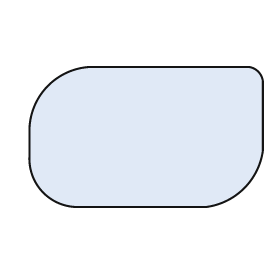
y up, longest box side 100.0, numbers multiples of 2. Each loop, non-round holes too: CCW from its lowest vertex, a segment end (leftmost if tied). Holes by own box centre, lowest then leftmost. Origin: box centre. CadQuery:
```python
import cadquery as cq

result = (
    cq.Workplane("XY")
    .moveTo(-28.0, -30.0)
    .lineTo(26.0, -30.0)
    .threePointArc((42.0, -22.0), (50.0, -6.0))
    .lineTo(50.0, 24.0)
    .threePointArc((48.0, 28.0), (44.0, 30.0))
    .lineTo(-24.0, 30.0)
    .threePointArc((-42.0, 22.0), (-50.0, 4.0))
    .lineTo(-50.0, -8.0)
    .threePointArc((-44.0, -24.0), (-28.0, -30.0))
    .close()
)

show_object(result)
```